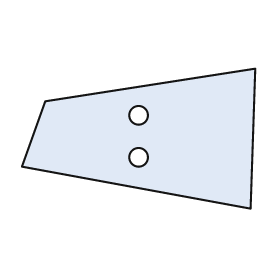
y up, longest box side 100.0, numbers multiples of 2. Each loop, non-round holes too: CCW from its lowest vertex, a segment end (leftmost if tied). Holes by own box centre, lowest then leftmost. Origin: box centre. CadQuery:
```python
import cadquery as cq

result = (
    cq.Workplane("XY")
    .moveTo(48.0, -30.0)
    .lineTo(50.0, 30.0)
    .lineTo(-40.0, 16.0)
    .lineTo(-50.0, -12.0)
    .close()
    .moveTo(0.0, -8.0)
    .circle(4.0)
    .moveTo(0.0, 10.0)
    .circle(4.0)
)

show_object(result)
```